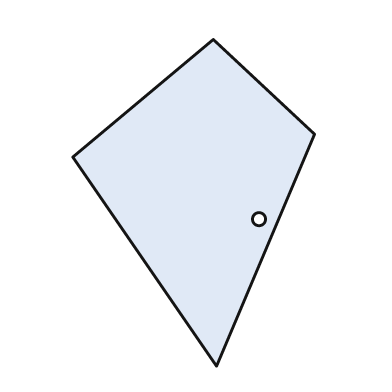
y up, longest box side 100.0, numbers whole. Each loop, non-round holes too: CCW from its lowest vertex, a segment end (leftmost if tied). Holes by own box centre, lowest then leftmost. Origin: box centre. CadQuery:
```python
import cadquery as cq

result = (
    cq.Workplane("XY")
    .moveTo(7.0, -50.0)
    .lineTo(37.0, 21.0)
    .lineTo(6.0, 50.0)
    .lineTo(-37.0, 14.0)
    .close()
    .moveTo(20.0, -5.0)
    .circle(2.0)
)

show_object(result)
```